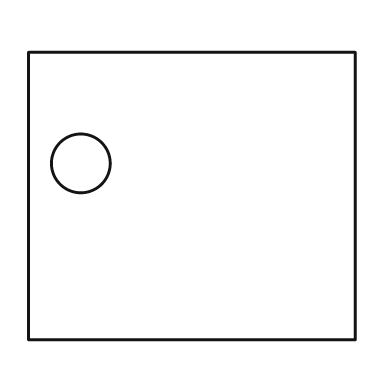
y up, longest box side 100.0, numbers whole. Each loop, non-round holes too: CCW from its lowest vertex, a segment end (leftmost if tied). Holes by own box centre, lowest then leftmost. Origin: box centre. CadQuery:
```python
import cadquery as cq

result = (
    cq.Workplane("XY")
    .moveTo(-50.0, -44.0)
    .lineTo(50.0, -44.0)
    .lineTo(50.0, 44.0)
    .lineTo(-50.0, 44.0)
    .close()
    .moveTo(-34.0, 10.0)
    .circle(9.0)
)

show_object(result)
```